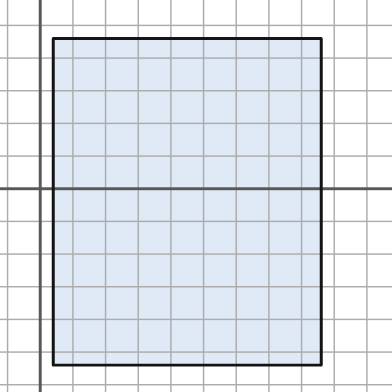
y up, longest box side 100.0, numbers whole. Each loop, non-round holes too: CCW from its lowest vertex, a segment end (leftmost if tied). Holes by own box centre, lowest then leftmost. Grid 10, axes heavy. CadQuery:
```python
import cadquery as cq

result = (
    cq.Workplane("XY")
    .moveTo(4.0, -54.0)
    .lineTo(86.0, -54.0)
    .lineTo(86.0, 46.0)
    .lineTo(4.0, 46.0)
    .close()
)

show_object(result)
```